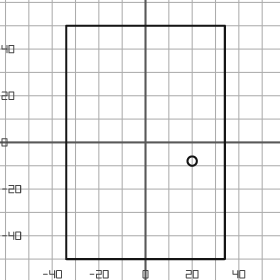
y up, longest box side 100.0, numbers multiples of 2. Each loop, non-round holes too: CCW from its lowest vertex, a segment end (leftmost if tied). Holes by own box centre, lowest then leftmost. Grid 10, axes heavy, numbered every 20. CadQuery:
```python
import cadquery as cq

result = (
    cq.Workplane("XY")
    .moveTo(-34.0, -50.0)
    .lineTo(34.0, -50.0)
    .lineTo(34.0, 50.0)
    .lineTo(-34.0, 50.0)
    .close()
    .moveTo(20.0, -8.0)
    .circle(2.0)
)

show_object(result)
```